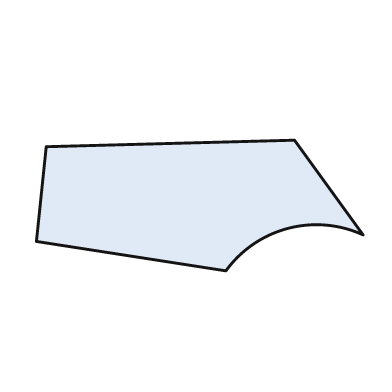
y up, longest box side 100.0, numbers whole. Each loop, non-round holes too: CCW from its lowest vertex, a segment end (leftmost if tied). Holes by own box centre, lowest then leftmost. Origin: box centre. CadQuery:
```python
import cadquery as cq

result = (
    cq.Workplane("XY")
    .moveTo(8.0, -20.0)
    .threePointArc((27.0, -7.0), (50.0, -9.0))
    .lineTo(29.0, 20.0)
    .lineTo(-47.0, 18.0)
    .lineTo(-50.0, -11.0)
    .close()
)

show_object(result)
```